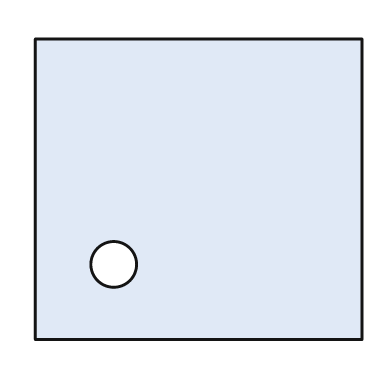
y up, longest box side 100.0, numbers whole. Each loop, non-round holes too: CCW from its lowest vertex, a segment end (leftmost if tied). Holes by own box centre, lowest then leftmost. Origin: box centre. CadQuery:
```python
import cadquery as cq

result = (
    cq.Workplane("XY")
    .moveTo(-50.0, -46.0)
    .lineTo(50.0, -46.0)
    .lineTo(50.0, 46.0)
    .lineTo(-50.0, 46.0)
    .close()
    .moveTo(-26.0, -23.0)
    .circle(7.0)
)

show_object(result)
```